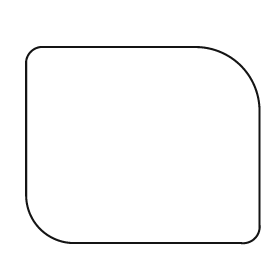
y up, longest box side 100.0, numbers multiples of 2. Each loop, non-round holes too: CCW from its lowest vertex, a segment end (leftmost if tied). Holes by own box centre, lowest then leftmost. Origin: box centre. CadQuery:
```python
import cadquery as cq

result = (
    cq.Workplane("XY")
    .moveTo(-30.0, -42.0)
    .lineTo(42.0, -42.0)
    .threePointArc((48.0, -40.0), (50.0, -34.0))
    .lineTo(50.0, 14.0)
    .threePointArc((42.0, 34.0), (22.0, 42.0))
    .lineTo(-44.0, 42.0)
    .threePointArc((-48.0, 40.0), (-50.0, 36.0))
    .lineTo(-50.0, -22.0)
    .threePointArc((-44.0, -36.0), (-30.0, -42.0))
    .close()
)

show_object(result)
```